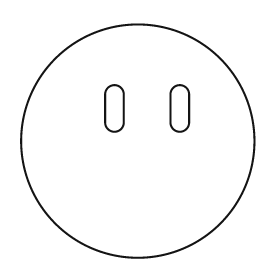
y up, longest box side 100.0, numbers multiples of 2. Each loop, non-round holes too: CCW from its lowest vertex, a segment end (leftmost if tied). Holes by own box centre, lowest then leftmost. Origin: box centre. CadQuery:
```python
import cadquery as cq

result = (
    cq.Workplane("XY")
    .moveTo(0.0, 0.0)
    .circle(50.0)
    .moveTo(-14.0, 8.0)
    .threePointArc((-10.0, 4.0), (-6.0, 8.0))
    .lineTo(-6.0, 20.0)
    .threePointArc((-10.0, 24.0), (-14.0, 20.0))
    .close()
    .moveTo(14.0, 8.0)
    .threePointArc((18.0, 4.0), (22.0, 8.0))
    .lineTo(22.0, 20.0)
    .threePointArc((18.0, 24.0), (14.0, 20.0))
    .close()
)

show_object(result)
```